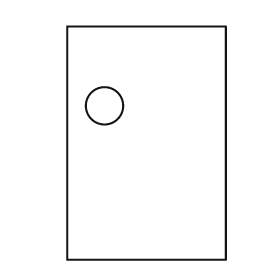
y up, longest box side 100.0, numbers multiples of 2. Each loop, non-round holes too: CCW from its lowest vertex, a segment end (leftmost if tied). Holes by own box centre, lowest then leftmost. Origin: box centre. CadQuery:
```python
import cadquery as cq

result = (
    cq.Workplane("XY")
    .moveTo(-34.0, -50.0)
    .lineTo(34.0, -50.0)
    .lineTo(34.0, 50.0)
    .lineTo(-34.0, 50.0)
    .close()
    .moveTo(-18.0, 16.0)
    .circle(8.0)
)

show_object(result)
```